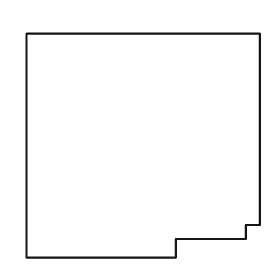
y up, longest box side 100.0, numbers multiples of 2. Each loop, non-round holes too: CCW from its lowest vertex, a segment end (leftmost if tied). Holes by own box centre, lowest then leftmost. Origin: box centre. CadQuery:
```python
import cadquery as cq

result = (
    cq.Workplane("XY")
    .moveTo(-50.0, -48.0)
    .lineTo(14.0, -48.0)
    .lineTo(14.0, -40.0)
    .lineTo(44.0, -40.0)
    .lineTo(44.0, -34.0)
    .lineTo(50.0, -34.0)
    .lineTo(50.0, 48.0)
    .lineTo(-50.0, 48.0)
    .close()
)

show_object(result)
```